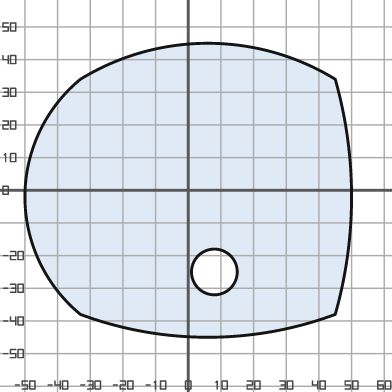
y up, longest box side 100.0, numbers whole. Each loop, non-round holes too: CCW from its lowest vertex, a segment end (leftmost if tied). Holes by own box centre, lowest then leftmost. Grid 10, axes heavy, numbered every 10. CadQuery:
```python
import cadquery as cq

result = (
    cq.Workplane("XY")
    .moveTo(-33.0, -38.0)
    .threePointArc((6.0, -45.0), (45.0, -38.0))
    .threePointArc((50.0, -2.0), (45.0, 34.0))
    .threePointArc((6.0, 45.0), (-33.0, 34.0))
    .threePointArc((-50.0, -2.0), (-33.0, -38.0))
    .close()
    .moveTo(8.0, -25.0)
    .circle(7.0)
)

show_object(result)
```